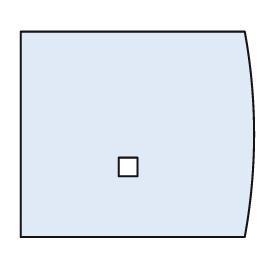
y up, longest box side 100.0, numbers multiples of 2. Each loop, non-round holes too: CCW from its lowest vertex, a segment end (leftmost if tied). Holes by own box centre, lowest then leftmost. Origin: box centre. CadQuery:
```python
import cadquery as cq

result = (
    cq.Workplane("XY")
    .moveTo(-50.0, -44.0)
    .lineTo(46.0, -44.0)
    .threePointArc((50.0, 0.0), (46.0, 44.0))
    .lineTo(-50.0, 44.0)
    .close()
    .moveTo(-8.0, -18.0)
    .lineTo(0.0, -18.0)
    .lineTo(0.0, -10.0)
    .lineTo(-8.0, -10.0)
    .close()
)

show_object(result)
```